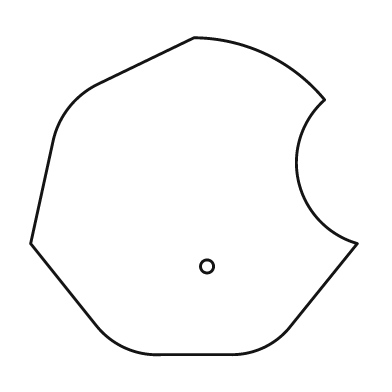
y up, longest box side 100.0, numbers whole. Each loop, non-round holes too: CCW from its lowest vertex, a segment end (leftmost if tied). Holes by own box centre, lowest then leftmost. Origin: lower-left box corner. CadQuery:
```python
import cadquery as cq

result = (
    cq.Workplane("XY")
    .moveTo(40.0, 0.0)
    .lineTo(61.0, 0.0)
    .threePointArc((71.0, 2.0), (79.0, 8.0))
    .lineTo(100.0, 34.0)
    .threePointArc((82.0, 53.0), (90.0, 78.0))
    .threePointArc((72.0, 92.0), (50.0, 97.0))
    .lineTo(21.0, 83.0)
    .threePointArc((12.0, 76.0), (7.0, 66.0))
    .lineTo(0.0, 34.0)
    .lineTo(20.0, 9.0)
    .threePointArc((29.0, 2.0), (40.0, 0.0))
    .close()
    .moveTo(54.0, 27.0)
    .circle(2.0)
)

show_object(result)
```